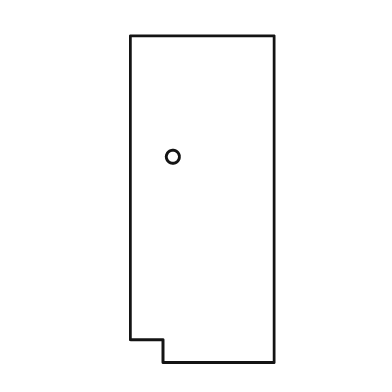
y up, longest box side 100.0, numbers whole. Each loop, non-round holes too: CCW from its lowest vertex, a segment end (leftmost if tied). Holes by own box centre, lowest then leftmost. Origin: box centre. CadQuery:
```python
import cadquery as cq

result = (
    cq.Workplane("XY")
    .moveTo(-12.0, -50.0)
    .lineTo(22.0, -50.0)
    .lineTo(22.0, 50.0)
    .lineTo(-22.0, 50.0)
    .lineTo(-22.0, -43.0)
    .lineTo(-12.0, -43.0)
    .close()
    .moveTo(-9.0, 13.0)
    .circle(2.0)
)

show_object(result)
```